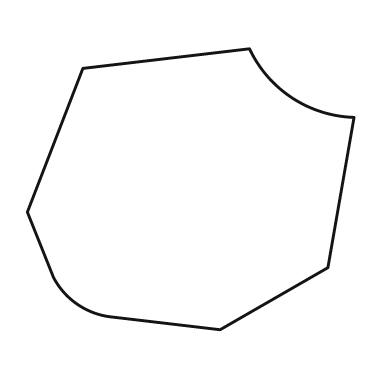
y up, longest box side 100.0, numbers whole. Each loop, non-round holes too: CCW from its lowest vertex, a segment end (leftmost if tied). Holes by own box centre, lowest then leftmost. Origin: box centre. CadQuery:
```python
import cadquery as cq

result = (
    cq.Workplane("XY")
    .moveTo(9.0, -43.0)
    .lineTo(42.0, -24.0)
    .lineTo(50.0, 22.0)
    .threePointArc((31.0, 28.0), (18.0, 43.0))
    .lineTo(-33.0, 37.0)
    .lineTo(-50.0, -7.0)
    .lineTo(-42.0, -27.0)
    .threePointArc((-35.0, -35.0), (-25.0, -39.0))
    .close()
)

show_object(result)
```